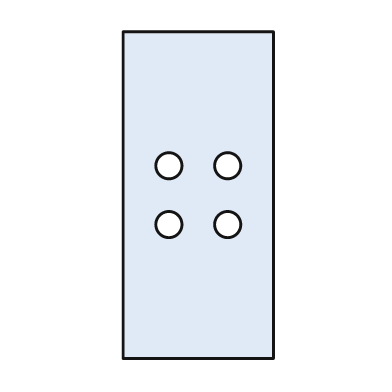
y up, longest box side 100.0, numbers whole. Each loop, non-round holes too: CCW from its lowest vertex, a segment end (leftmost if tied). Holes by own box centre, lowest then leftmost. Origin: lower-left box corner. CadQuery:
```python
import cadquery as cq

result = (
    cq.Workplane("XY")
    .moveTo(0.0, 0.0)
    .lineTo(46.0, 0.0)
    .lineTo(46.0, 100.0)
    .lineTo(0.0, 100.0)
    .close()
    .moveTo(14.0, 41.0)
    .circle(4.0)
    .moveTo(32.0, 41.0)
    .circle(4.0)
    .moveTo(14.0, 59.0)
    .circle(4.0)
    .moveTo(32.0, 59.0)
    .circle(4.0)
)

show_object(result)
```